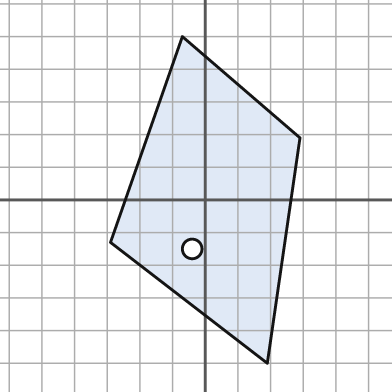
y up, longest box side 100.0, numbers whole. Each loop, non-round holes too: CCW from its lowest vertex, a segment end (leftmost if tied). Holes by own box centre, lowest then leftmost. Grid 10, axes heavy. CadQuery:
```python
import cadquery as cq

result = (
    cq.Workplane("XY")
    .moveTo(19.0, -50.0)
    .lineTo(29.0, 19.0)
    .lineTo(-7.0, 50.0)
    .lineTo(-29.0, -13.0)
    .close()
    .moveTo(-4.0, -15.0)
    .circle(3.0)
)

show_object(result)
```